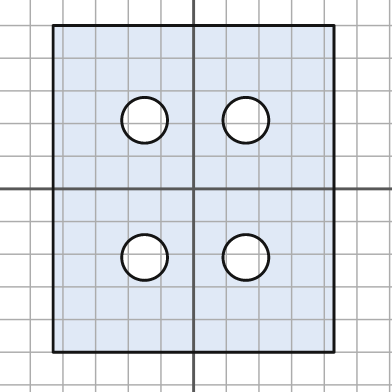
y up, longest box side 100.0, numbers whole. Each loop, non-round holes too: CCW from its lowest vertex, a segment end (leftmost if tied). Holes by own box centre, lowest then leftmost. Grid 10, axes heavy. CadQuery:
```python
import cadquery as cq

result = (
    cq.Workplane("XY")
    .moveTo(-43.0, -50.0)
    .lineTo(43.0, -50.0)
    .lineTo(43.0, 50.0)
    .lineTo(-43.0, 50.0)
    .close()
    .moveTo(-15.0, -21.0)
    .circle(7.0)
    .moveTo(16.0, -21.0)
    .circle(7.0)
    .moveTo(-15.0, 21.0)
    .circle(7.0)
    .moveTo(16.0, 21.0)
    .circle(7.0)
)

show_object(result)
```